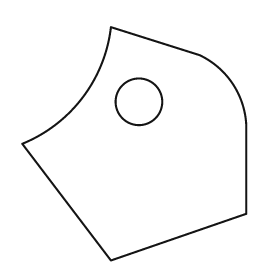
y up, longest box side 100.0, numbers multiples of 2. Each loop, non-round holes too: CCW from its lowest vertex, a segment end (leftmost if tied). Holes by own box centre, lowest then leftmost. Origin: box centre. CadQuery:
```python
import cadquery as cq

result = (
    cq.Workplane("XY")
    .moveTo(-10.0, -50.0)
    .lineTo(48.0, -30.0)
    .lineTo(48.0, 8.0)
    .threePointArc((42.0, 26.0), (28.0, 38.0))
    .lineTo(-10.0, 50.0)
    .threePointArc((-22.0, 20.0), (-48.0, 0.0))
    .close()
    .moveTo(2.0, 18.0)
    .circle(10.0)
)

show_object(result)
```